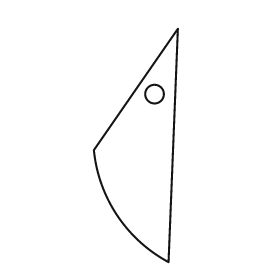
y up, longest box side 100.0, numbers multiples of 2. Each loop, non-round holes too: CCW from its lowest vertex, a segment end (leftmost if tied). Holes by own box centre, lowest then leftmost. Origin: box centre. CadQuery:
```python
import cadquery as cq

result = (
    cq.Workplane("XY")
    .moveTo(14.0, -50.0)
    .lineTo(18.0, 50.0)
    .lineTo(-18.0, -2.0)
    .threePointArc((-8.0, -30.0), (14.0, -50.0))
    .close()
    .moveTo(8.0, 22.0)
    .circle(4.0)
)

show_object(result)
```